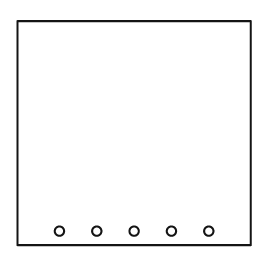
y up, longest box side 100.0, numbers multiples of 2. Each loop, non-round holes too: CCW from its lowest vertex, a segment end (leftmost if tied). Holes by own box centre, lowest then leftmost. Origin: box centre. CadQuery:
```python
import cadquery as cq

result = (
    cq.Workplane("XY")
    .moveTo(-50.0, -48.0)
    .lineTo(50.0, -48.0)
    .lineTo(50.0, 48.0)
    .lineTo(-50.0, 48.0)
    .close()
    .moveTo(-32.0, -42.0)
    .circle(2.0)
    .moveTo(-16.0, -42.0)
    .circle(2.0)
    .moveTo(0.0, -42.0)
    .circle(2.0)
    .moveTo(16.0, -42.0)
    .circle(2.0)
    .moveTo(32.0, -42.0)
    .circle(2.0)
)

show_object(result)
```